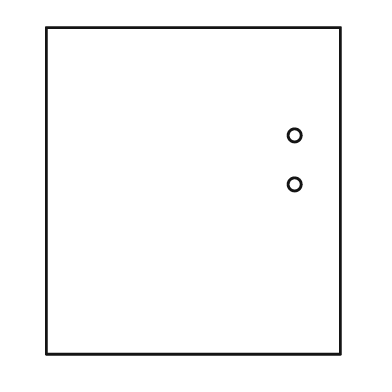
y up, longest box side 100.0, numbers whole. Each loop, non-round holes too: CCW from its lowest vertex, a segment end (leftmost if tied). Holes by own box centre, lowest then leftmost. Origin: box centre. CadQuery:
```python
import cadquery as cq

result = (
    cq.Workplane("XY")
    .moveTo(-45.0, -50.0)
    .lineTo(45.0, -50.0)
    .lineTo(45.0, 50.0)
    .lineTo(-45.0, 50.0)
    .close()
    .moveTo(31.0, 2.0)
    .circle(2.0)
    .moveTo(31.0, 17.0)
    .circle(2.0)
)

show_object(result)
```